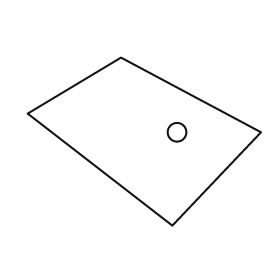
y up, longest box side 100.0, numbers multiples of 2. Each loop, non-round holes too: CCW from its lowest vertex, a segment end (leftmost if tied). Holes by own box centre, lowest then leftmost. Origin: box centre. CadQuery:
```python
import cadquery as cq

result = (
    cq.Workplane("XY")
    .moveTo(12.0, -36.0)
    .lineTo(50.0, 4.0)
    .lineTo(-10.0, 36.0)
    .lineTo(-50.0, 12.0)
    .close()
    .moveTo(14.0, 4.0)
    .circle(4.0)
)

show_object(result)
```